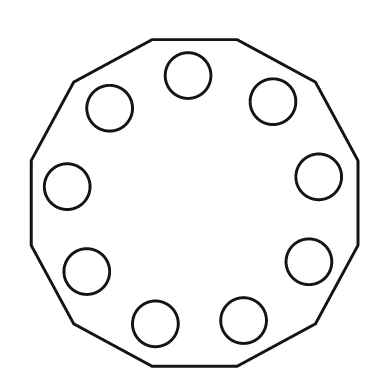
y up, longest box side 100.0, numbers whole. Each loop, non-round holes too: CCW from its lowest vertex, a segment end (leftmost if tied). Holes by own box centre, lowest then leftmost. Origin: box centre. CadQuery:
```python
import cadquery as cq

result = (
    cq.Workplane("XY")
    .moveTo(-13.0, -50.0)
    .lineTo(13.0, -50.0)
    .lineTo(37.0, -37.0)
    .lineTo(50.0, -13.0)
    .lineTo(50.0, 13.0)
    .lineTo(37.0, 37.0)
    .lineTo(13.0, 50.0)
    .lineTo(-13.0, 50.0)
    .lineTo(-37.0, 37.0)
    .lineTo(-50.0, 13.0)
    .lineTo(-50.0, -13.0)
    .lineTo(-37.0, -37.0)
    .close()
    .moveTo(-12.0, -37.0)
    .circle(7.0)
    .moveTo(15.0, -36.0)
    .circle(7.0)
    .moveTo(-33.0, -21.0)
    .circle(7.0)
    .moveTo(35.0, -18.0)
    .circle(7.0)
    .moveTo(-39.0, 5.0)
    .circle(7.0)
    .moveTo(38.0, 8.0)
    .circle(7.0)
    .moveTo(-26.0, 29.0)
    .circle(7.0)
    .moveTo(24.0, 31.0)
    .circle(7.0)
    .moveTo(-2.0, 39.0)
    .circle(7.0)
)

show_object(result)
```